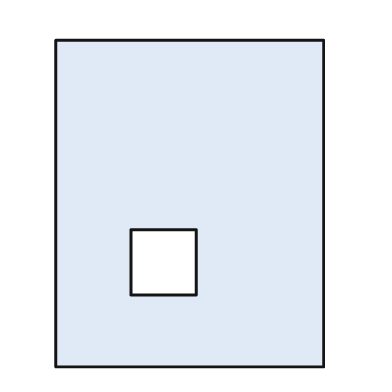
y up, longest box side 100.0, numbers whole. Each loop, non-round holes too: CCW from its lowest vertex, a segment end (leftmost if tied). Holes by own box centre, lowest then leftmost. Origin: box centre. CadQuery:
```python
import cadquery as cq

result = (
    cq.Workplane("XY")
    .moveTo(-41.0, -50.0)
    .lineTo(41.0, -50.0)
    .lineTo(41.0, 50.0)
    .lineTo(-41.0, 50.0)
    .close()
    .moveTo(-18.0, -28.0)
    .lineTo(2.0, -28.0)
    .lineTo(2.0, -8.0)
    .lineTo(-18.0, -8.0)
    .close()
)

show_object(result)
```